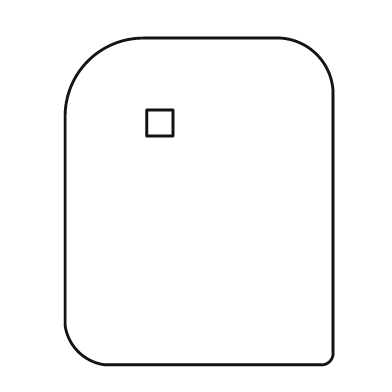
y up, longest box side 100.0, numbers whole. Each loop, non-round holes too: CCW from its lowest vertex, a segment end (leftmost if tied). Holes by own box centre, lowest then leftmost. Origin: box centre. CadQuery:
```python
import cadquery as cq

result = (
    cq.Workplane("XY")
    .moveTo(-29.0, -50.0)
    .lineTo(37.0, -50.0)
    .threePointArc((40.0, -49.0), (41.0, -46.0))
    .lineTo(41.0, 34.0)
    .threePointArc((36.0, 45.0), (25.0, 50.0))
    .lineTo(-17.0, 50.0)
    .threePointArc((-34.0, 43.0), (-41.0, 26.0))
    .lineTo(-41.0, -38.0)
    .threePointArc((-37.0, -46.0), (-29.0, -50.0))
    .close()
    .moveTo(-16.0, 20.0)
    .lineTo(-8.0, 20.0)
    .lineTo(-8.0, 28.0)
    .lineTo(-16.0, 28.0)
    .close()
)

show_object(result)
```